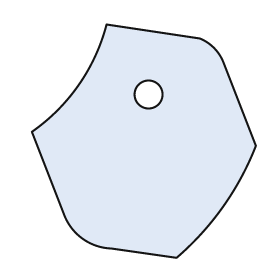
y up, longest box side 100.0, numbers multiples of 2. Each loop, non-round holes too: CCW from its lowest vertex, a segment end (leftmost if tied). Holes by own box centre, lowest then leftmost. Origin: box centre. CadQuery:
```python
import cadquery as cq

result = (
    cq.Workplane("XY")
    .moveTo(14.0, -50.0)
    .threePointArc((34.0, -28.0), (48.0, -2.0))
    .lineTo(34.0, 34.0)
    .threePointArc((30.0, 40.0), (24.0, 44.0))
    .lineTo(-16.0, 50.0)
    .threePointArc((-28.0, 24.0), (-48.0, 4.0))
    .lineTo(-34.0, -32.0)
    .threePointArc((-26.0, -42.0), (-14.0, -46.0))
    .close()
    .moveTo(2.0, 20.0)
    .circle(6.0)
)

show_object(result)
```